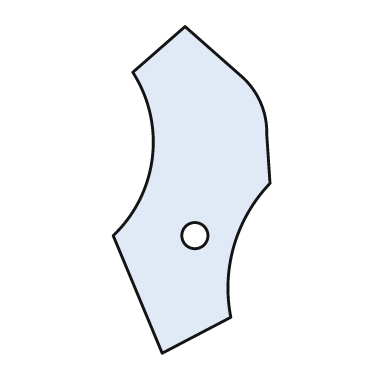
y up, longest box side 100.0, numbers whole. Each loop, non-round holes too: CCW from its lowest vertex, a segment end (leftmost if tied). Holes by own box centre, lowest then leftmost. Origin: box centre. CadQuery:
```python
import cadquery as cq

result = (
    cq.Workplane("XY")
    .moveTo(-9.0, -50.0)
    .lineTo(12.0, -39.0)
    .threePointArc((13.0, -17.0), (24.0, 2.0))
    .lineTo(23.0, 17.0)
    .threePointArc((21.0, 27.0), (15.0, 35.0))
    .lineTo(-2.0, 50.0)
    .lineTo(-18.0, 36.0)
    .threePointArc((-12.0, 10.0), (-24.0, -14.0))
    .close()
    .moveTo(1.0, -14.0)
    .circle(4.0)
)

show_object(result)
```